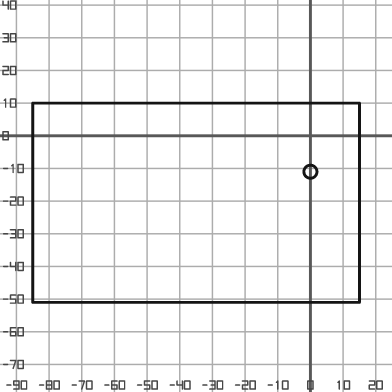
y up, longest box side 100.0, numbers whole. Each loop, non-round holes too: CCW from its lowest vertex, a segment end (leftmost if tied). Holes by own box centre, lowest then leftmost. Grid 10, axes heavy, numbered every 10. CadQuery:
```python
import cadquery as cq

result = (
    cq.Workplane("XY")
    .moveTo(-85.0, -51.0)
    .lineTo(15.0, -51.0)
    .lineTo(15.0, 10.0)
    .lineTo(-85.0, 10.0)
    .close()
    .moveTo(0.0, -11.0)
    .circle(2.0)
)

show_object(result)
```